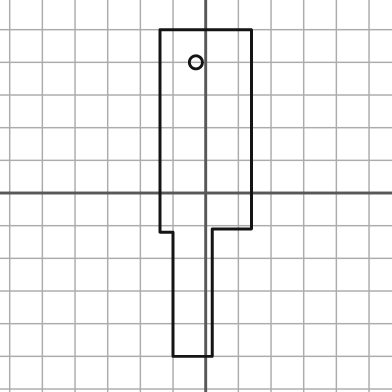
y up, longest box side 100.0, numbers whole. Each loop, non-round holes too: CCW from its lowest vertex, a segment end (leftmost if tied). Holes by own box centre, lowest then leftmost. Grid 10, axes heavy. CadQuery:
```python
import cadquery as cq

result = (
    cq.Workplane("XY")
    .moveTo(-10.0, -50.0)
    .lineTo(2.0, -50.0)
    .lineTo(2.0, -11.0)
    .lineTo(14.0, -11.0)
    .lineTo(14.0, 50.0)
    .lineTo(-14.0, 50.0)
    .lineTo(-14.0, -12.0)
    .lineTo(-10.0, -12.0)
    .close()
    .moveTo(-3.0, 40.0)
    .circle(2.0)
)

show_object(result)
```